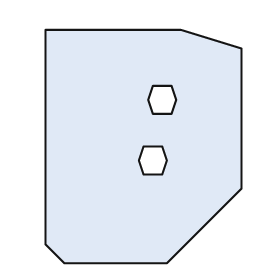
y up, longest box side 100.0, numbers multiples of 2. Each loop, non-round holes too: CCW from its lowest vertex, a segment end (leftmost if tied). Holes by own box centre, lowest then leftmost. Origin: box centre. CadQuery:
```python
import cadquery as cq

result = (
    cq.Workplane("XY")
    .moveTo(-34.0, -50.0)
    .lineTo(10.0, -50.0)
    .lineTo(42.0, -18.0)
    .lineTo(42.0, 42.0)
    .lineTo(16.0, 50.0)
    .lineTo(-42.0, 50.0)
    .lineTo(-42.0, -42.0)
    .close()
    .moveTo(0.0, -12.0)
    .lineTo(8.0, -12.0)
    .lineTo(10.0, -6.0)
    .lineTo(8.0, 0.0)
    .lineTo(0.0, 0.0)
    .lineTo(-2.0, -6.0)
    .close()
    .moveTo(4.0, 14.0)
    .lineTo(12.0, 14.0)
    .lineTo(14.0, 20.0)
    .lineTo(12.0, 26.0)
    .lineTo(4.0, 26.0)
    .lineTo(2.0, 20.0)
    .close()
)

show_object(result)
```